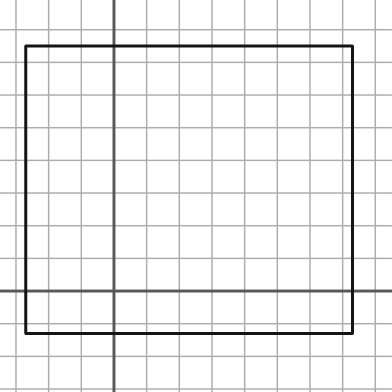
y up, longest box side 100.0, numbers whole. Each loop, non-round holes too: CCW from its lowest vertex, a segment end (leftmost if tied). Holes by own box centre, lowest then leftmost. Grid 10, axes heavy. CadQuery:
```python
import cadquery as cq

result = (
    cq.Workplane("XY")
    .moveTo(-27.0, -13.0)
    .lineTo(73.0, -13.0)
    .lineTo(73.0, 75.0)
    .lineTo(-27.0, 75.0)
    .close()
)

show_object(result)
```